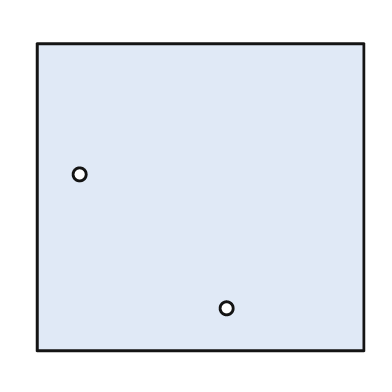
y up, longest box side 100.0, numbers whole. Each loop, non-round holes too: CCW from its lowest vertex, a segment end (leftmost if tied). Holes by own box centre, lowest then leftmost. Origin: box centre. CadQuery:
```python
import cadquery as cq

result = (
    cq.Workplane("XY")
    .moveTo(-50.0, -47.0)
    .lineTo(50.0, -47.0)
    .lineTo(50.0, 47.0)
    .lineTo(-50.0, 47.0)
    .close()
    .moveTo(8.0, -34.0)
    .circle(2.0)
    .moveTo(-37.0, 7.0)
    .circle(2.0)
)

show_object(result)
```